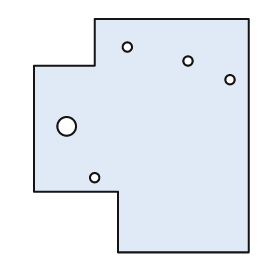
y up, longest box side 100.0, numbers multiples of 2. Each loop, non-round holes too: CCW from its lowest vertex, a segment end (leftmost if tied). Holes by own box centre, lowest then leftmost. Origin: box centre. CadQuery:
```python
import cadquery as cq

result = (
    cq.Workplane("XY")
    .moveTo(-10.0, -50.0)
    .lineTo(46.0, -50.0)
    .lineTo(46.0, 50.0)
    .lineTo(-20.0, 50.0)
    .lineTo(-20.0, 30.0)
    .lineTo(-46.0, 30.0)
    .lineTo(-46.0, -24.0)
    .lineTo(-10.0, -24.0)
    .close()
    .moveTo(-20.0, -18.0)
    .circle(2.0)
    .moveTo(-32.0, 4.0)
    .circle(4.0)
    .moveTo(38.0, 24.0)
    .circle(2.0)
    .moveTo(20.0, 32.0)
    .circle(2.0)
    .moveTo(-6.0, 38.0)
    .circle(2.0)
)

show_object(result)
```